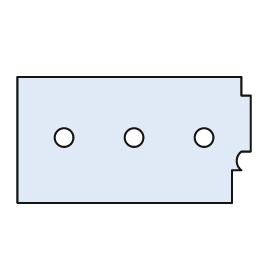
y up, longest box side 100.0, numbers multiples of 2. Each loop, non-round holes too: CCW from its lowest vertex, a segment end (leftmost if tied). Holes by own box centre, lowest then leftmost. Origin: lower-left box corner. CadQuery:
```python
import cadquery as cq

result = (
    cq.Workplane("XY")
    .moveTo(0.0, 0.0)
    .lineTo(92.0, 0.0)
    .lineTo(92.0, 14.0)
    .lineTo(96.0, 14.0)
    .threePointArc((94.0, 18.0), (96.0, 22.0))
    .lineTo(100.0, 22.0)
    .lineTo(100.0, 46.0)
    .lineTo(96.0, 46.0)
    .lineTo(96.0, 54.0)
    .lineTo(0.0, 54.0)
    .close()
    .moveTo(20.0, 28.0)
    .circle(4.0)
    .moveTo(50.0, 28.0)
    .circle(4.0)
    .moveTo(80.0, 28.0)
    .circle(4.0)
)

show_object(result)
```